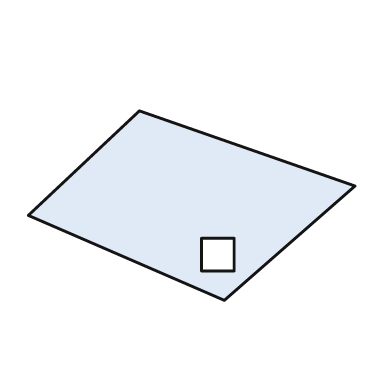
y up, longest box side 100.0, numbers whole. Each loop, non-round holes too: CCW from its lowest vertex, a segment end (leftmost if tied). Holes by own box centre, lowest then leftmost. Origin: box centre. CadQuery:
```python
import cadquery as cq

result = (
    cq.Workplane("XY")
    .moveTo(10.0, -29.0)
    .lineTo(50.0, 6.0)
    .lineTo(-16.0, 29.0)
    .lineTo(-50.0, -3.0)
    .close()
    .moveTo(3.0, -20.0)
    .lineTo(13.0, -20.0)
    .lineTo(13.0, -10.0)
    .lineTo(3.0, -10.0)
    .close()
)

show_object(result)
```